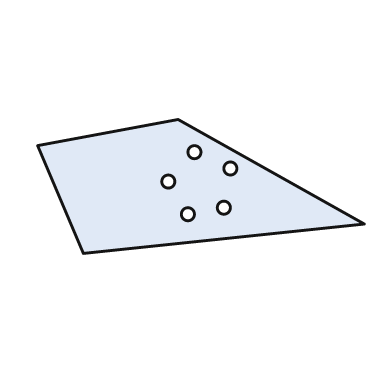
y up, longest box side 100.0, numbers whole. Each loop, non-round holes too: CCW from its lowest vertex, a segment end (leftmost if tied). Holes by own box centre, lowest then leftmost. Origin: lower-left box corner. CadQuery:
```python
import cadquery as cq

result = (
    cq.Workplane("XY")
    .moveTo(14.0, 0.0)
    .lineTo(100.0, 9.0)
    .lineTo(43.0, 41.0)
    .lineTo(0.0, 33.0)
    .close()
    .moveTo(46.0, 12.0)
    .circle(2.0)
    .moveTo(57.0, 14.0)
    .circle(2.0)
    .moveTo(40.0, 22.0)
    .circle(2.0)
    .moveTo(59.0, 26.0)
    .circle(2.0)
    .moveTo(48.0, 31.0)
    .circle(2.0)
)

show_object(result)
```